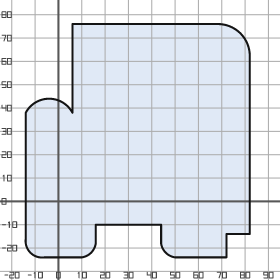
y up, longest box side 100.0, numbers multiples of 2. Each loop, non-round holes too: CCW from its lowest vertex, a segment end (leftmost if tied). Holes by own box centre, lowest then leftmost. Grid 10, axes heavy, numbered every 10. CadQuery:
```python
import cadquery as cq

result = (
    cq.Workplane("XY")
    .moveTo(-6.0, -24.0)
    .lineTo(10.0, -24.0)
    .threePointArc((14.0, -22.0), (16.0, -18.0))
    .lineTo(16.0, -10.0)
    .lineTo(44.0, -10.0)
    .lineTo(44.0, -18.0)
    .threePointArc((46.0, -22.0), (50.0, -24.0))
    .lineTo(72.0, -24.0)
    .lineTo(72.0, -14.0)
    .lineTo(82.0, -14.0)
    .lineTo(82.0, 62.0)
    .threePointArc((78.0, 72.0), (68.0, 76.0))
    .lineTo(6.0, 76.0)
    .lineTo(6.0, 38.0)
    .threePointArc((-4.0, 44.0), (-14.0, 38.0))
    .lineTo(-14.0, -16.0)
    .threePointArc((-12.0, -22.0), (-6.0, -24.0))
    .close()
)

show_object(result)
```